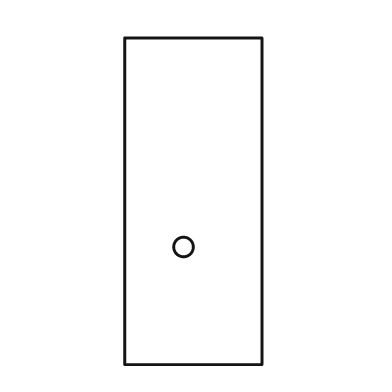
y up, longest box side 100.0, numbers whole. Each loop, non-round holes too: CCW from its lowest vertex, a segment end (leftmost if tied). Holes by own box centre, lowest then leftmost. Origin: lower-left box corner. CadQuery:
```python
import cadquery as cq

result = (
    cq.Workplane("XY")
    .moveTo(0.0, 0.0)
    .lineTo(42.0, 0.0)
    .lineTo(42.0, 100.0)
    .lineTo(0.0, 100.0)
    .close()
    .moveTo(18.0, 36.0)
    .circle(3.0)
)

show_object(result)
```